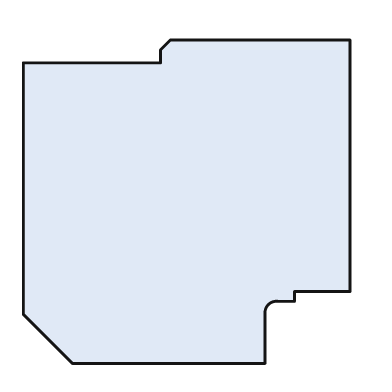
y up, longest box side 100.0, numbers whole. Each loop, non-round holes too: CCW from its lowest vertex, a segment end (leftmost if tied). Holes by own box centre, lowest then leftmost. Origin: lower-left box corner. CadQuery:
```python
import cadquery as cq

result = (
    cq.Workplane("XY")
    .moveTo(15.0, 0.0)
    .lineTo(74.0, 0.0)
    .lineTo(74.0, 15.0)
    .threePointArc((75.0, 18.0), (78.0, 19.0))
    .lineTo(83.0, 19.0)
    .lineTo(83.0, 22.0)
    .lineTo(100.0, 22.0)
    .lineTo(100.0, 99.0)
    .lineTo(45.0, 99.0)
    .lineTo(42.0, 96.0)
    .lineTo(42.0, 92.0)
    .lineTo(0.0, 92.0)
    .lineTo(0.0, 15.0)
    .close()
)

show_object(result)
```